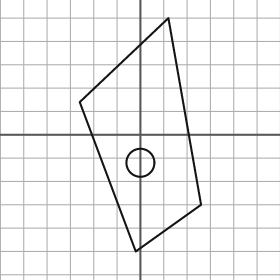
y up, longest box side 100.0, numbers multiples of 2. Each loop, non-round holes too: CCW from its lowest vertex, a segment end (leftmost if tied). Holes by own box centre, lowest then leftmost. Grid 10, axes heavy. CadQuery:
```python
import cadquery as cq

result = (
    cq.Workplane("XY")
    .moveTo(-2.0, -50.0)
    .lineTo(26.0, -30.0)
    .lineTo(12.0, 50.0)
    .lineTo(-26.0, 14.0)
    .close()
    .moveTo(0.0, -12.0)
    .circle(6.0)
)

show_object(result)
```